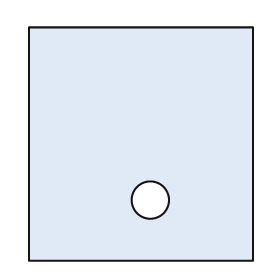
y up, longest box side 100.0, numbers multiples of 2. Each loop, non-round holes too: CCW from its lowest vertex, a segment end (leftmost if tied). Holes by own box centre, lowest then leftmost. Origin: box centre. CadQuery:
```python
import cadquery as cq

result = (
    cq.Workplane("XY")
    .moveTo(-48.0, -50.0)
    .lineTo(48.0, -50.0)
    .lineTo(48.0, 50.0)
    .lineTo(-48.0, 50.0)
    .close()
    .moveTo(4.0, -24.0)
    .circle(8.0)
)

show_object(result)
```